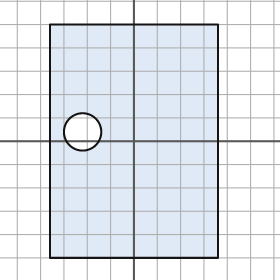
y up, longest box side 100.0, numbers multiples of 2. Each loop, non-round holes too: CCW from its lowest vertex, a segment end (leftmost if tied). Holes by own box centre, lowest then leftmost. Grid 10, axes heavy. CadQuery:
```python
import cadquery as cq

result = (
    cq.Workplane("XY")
    .moveTo(-36.0, -50.0)
    .lineTo(36.0, -50.0)
    .lineTo(36.0, 50.0)
    .lineTo(-36.0, 50.0)
    .close()
    .moveTo(-22.0, 4.0)
    .circle(8.0)
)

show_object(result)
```